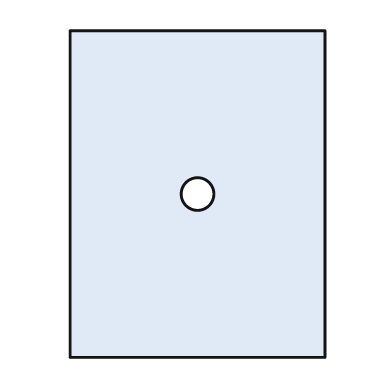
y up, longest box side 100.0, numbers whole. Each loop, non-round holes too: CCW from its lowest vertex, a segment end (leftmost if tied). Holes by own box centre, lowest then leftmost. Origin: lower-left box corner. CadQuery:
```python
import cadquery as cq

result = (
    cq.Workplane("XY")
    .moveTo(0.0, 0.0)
    .lineTo(78.0, 0.0)
    .lineTo(78.0, 100.0)
    .lineTo(0.0, 100.0)
    .close()
    .moveTo(39.0, 50.0)
    .circle(5.0)
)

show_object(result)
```